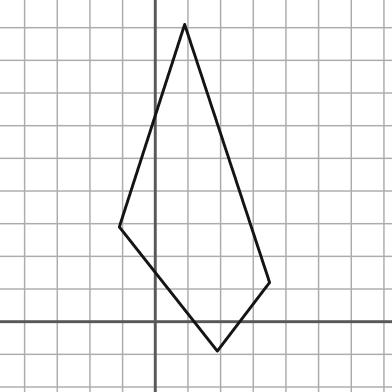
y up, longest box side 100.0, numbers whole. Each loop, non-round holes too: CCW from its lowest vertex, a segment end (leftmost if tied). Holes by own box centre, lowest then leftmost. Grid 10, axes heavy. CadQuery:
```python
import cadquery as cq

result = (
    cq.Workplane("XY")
    .moveTo(19.0, -9.0)
    .lineTo(35.0, 12.0)
    .lineTo(9.0, 91.0)
    .lineTo(-11.0, 29.0)
    .close()
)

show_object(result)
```